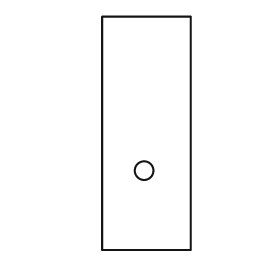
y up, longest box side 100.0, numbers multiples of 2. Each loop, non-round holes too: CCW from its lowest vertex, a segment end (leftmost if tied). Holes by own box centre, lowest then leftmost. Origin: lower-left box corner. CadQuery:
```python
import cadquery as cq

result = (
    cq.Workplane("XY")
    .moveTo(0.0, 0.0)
    .lineTo(38.0, 0.0)
    .lineTo(38.0, 100.0)
    .lineTo(0.0, 100.0)
    .close()
    .moveTo(18.0, 34.0)
    .circle(4.0)
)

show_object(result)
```